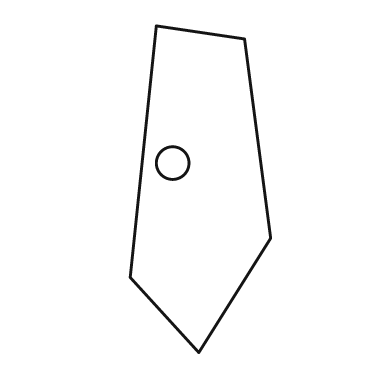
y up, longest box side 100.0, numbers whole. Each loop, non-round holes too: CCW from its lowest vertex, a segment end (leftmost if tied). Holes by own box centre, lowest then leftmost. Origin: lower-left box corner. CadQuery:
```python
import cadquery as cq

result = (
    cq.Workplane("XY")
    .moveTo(21.0, 0.0)
    .lineTo(43.0, 35.0)
    .lineTo(35.0, 96.0)
    .lineTo(8.0, 100.0)
    .lineTo(0.0, 23.0)
    .close()
    .moveTo(13.0, 58.0)
    .circle(5.0)
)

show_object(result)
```